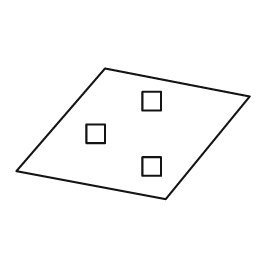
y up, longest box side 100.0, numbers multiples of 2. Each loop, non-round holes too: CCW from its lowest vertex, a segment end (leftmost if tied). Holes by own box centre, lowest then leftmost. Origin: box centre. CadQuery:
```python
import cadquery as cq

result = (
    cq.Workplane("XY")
    .moveTo(14.0, -28.0)
    .lineTo(50.0, 16.0)
    .lineTo(-12.0, 28.0)
    .lineTo(-50.0, -16.0)
    .close()
    .moveTo(4.0, -18.0)
    .lineTo(12.0, -18.0)
    .lineTo(12.0, -10.0)
    .lineTo(4.0, -10.0)
    .close()
    .moveTo(-20.0, -4.0)
    .lineTo(-12.0, -4.0)
    .lineTo(-12.0, 4.0)
    .lineTo(-20.0, 4.0)
    .close()
    .moveTo(4.0, 10.0)
    .lineTo(12.0, 10.0)
    .lineTo(12.0, 18.0)
    .lineTo(4.0, 18.0)
    .close()
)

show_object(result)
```